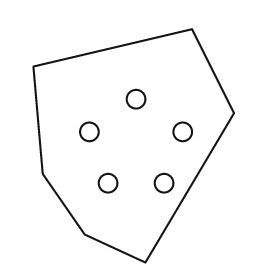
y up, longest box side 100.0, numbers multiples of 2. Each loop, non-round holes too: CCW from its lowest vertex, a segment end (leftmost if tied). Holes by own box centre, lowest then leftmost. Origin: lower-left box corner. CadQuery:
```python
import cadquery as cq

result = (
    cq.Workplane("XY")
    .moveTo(48.0, 0.0)
    .lineTo(86.0, 64.0)
    .lineTo(68.0, 100.0)
    .lineTo(0.0, 84.0)
    .lineTo(4.0, 38.0)
    .lineTo(22.0, 12.0)
    .close()
    .moveTo(32.0, 34.0)
    .circle(4.0)
    .moveTo(56.0, 34.0)
    .circle(4.0)
    .moveTo(24.0, 56.0)
    .circle(4.0)
    .moveTo(64.0, 56.0)
    .circle(4.0)
    .moveTo(44.0, 70.0)
    .circle(4.0)
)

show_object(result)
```